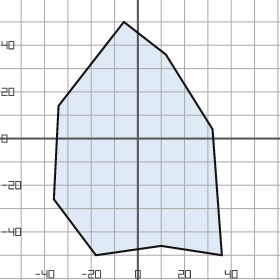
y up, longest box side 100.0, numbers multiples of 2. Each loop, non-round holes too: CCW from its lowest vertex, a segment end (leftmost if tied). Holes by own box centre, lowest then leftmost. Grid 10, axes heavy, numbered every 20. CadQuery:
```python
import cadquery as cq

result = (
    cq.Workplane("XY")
    .moveTo(-18.0, -50.0)
    .lineTo(10.0, -46.0)
    .lineTo(36.0, -50.0)
    .lineTo(32.0, 4.0)
    .lineTo(12.0, 36.0)
    .lineTo(-6.0, 50.0)
    .lineTo(-34.0, 14.0)
    .lineTo(-36.0, -26.0)
    .close()
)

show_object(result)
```